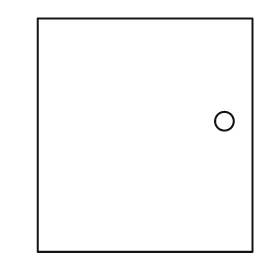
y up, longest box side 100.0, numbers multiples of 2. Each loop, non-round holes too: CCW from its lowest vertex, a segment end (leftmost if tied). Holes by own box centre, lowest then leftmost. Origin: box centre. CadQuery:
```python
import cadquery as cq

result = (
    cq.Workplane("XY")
    .moveTo(-46.0, -50.0)
    .lineTo(46.0, -50.0)
    .lineTo(46.0, 50.0)
    .lineTo(-46.0, 50.0)
    .close()
    .moveTo(34.0, 6.0)
    .circle(4.0)
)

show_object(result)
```